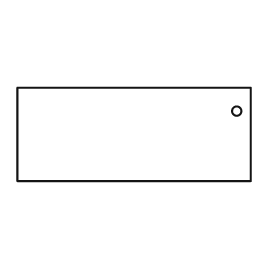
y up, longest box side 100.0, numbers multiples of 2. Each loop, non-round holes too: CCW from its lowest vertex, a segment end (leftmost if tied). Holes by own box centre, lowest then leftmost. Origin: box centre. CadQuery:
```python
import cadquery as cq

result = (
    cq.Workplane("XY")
    .moveTo(-50.0, -20.0)
    .lineTo(50.0, -20.0)
    .lineTo(50.0, 20.0)
    .lineTo(-50.0, 20.0)
    .close()
    .moveTo(44.0, 10.0)
    .circle(2.0)
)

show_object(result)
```